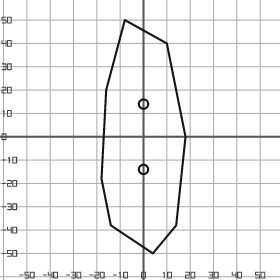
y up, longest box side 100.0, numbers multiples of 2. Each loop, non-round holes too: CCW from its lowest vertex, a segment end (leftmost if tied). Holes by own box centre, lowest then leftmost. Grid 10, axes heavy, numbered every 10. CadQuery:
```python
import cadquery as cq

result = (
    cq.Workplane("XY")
    .moveTo(4.0, -50.0)
    .lineTo(14.0, -38.0)
    .lineTo(18.0, 0.0)
    .lineTo(10.0, 40.0)
    .lineTo(-8.0, 50.0)
    .lineTo(-16.0, 20.0)
    .lineTo(-18.0, -18.0)
    .lineTo(-14.0, -38.0)
    .close()
    .moveTo(0.0, -14.0)
    .circle(2.0)
    .moveTo(0.0, 14.0)
    .circle(2.0)
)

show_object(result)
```